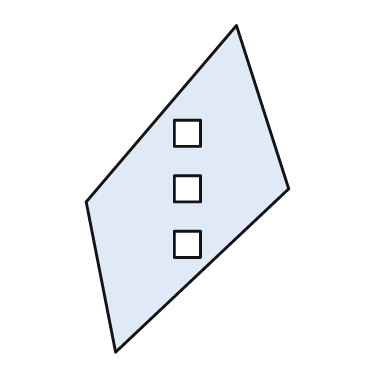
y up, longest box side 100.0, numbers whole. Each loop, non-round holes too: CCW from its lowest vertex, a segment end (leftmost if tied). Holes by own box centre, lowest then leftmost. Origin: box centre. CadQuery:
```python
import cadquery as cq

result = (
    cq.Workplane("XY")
    .moveTo(-22.0, -50.0)
    .lineTo(31.0, 0.0)
    .lineTo(15.0, 50.0)
    .lineTo(-31.0, -4.0)
    .close()
    .moveTo(-4.0, -21.0)
    .lineTo(4.0, -21.0)
    .lineTo(4.0, -13.0)
    .lineTo(-4.0, -13.0)
    .close()
    .moveTo(-4.0, -4.0)
    .lineTo(4.0, -4.0)
    .lineTo(4.0, 4.0)
    .lineTo(-4.0, 4.0)
    .close()
    .moveTo(-4.0, 13.0)
    .lineTo(4.0, 13.0)
    .lineTo(4.0, 21.0)
    .lineTo(-4.0, 21.0)
    .close()
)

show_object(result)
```